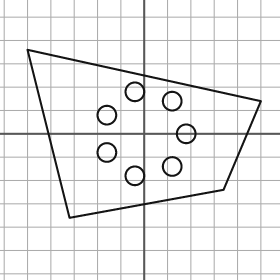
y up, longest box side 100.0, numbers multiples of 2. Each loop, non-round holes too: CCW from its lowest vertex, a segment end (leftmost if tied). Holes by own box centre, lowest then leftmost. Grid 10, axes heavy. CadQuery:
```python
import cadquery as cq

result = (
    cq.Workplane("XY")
    .moveTo(-32.0, -36.0)
    .lineTo(34.0, -24.0)
    .lineTo(50.0, 14.0)
    .lineTo(-50.0, 36.0)
    .close()
    .moveTo(-4.0, -18.0)
    .circle(4.0)
    .moveTo(12.0, -14.0)
    .circle(4.0)
    .moveTo(-16.0, -8.0)
    .circle(4.0)
    .moveTo(18.0, 0.0)
    .circle(4.0)
    .moveTo(-16.0, 8.0)
    .circle(4.0)
    .moveTo(12.0, 14.0)
    .circle(4.0)
    .moveTo(-4.0, 18.0)
    .circle(4.0)
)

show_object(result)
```